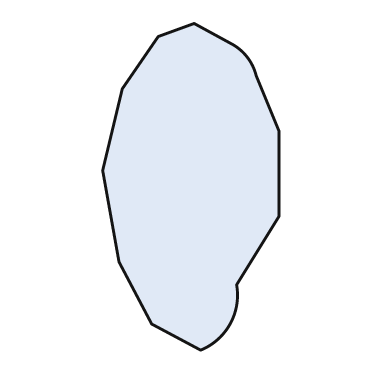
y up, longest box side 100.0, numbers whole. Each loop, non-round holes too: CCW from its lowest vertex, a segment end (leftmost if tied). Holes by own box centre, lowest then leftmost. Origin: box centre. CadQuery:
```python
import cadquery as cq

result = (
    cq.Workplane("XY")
    .moveTo(3.0, -50.0)
    .threePointArc((12.0, -42.0), (14.0, -30.0))
    .lineTo(27.0, -9.0)
    .lineTo(27.0, 17.0)
    .lineTo(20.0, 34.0)
    .threePointArc((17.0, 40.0), (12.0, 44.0))
    .lineTo(1.0, 50.0)
    .lineTo(-10.0, 46.0)
    .lineTo(-21.0, 30.0)
    .lineTo(-27.0, 5.0)
    .lineTo(-22.0, -23.0)
    .lineTo(-12.0, -42.0)
    .close()
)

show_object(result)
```